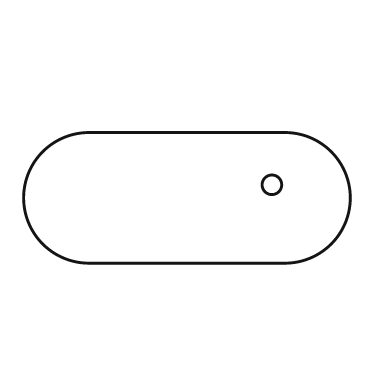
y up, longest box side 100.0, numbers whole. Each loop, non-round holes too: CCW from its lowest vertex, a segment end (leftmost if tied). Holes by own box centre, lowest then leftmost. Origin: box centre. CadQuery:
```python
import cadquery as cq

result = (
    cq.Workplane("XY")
    .moveTo(-30.0, -20.0)
    .lineTo(30.0, -20.0)
    .threePointArc((50.0, 0.0), (30.0, 20.0))
    .lineTo(-30.0, 20.0)
    .threePointArc((-50.0, 0.0), (-30.0, -20.0))
    .close()
    .moveTo(26.0, 4.0)
    .circle(3.0)
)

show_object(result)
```